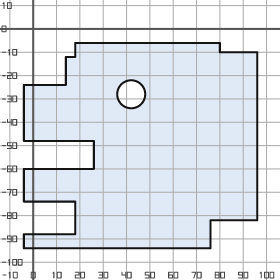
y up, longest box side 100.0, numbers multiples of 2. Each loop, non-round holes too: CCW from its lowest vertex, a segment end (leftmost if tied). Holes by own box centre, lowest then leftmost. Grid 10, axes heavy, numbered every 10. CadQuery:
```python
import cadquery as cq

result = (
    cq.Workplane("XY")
    .moveTo(-4.0, -94.0)
    .lineTo(76.0, -94.0)
    .lineTo(76.0, -82.0)
    .lineTo(96.0, -82.0)
    .lineTo(96.0, -10.0)
    .lineTo(80.0, -10.0)
    .lineTo(80.0, -6.0)
    .lineTo(18.0, -6.0)
    .lineTo(18.0, -12.0)
    .lineTo(14.0, -12.0)
    .lineTo(14.0, -24.0)
    .lineTo(-4.0, -24.0)
    .lineTo(-4.0, -48.0)
    .lineTo(26.0, -48.0)
    .lineTo(26.0, -60.0)
    .lineTo(-4.0, -60.0)
    .lineTo(-4.0, -74.0)
    .lineTo(18.0, -74.0)
    .lineTo(18.0, -88.0)
    .lineTo(-4.0, -88.0)
    .close()
    .moveTo(42.0, -28.0)
    .circle(6.0)
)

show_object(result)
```